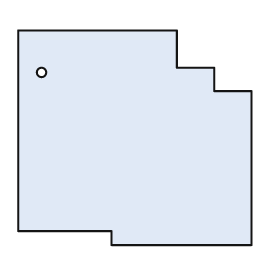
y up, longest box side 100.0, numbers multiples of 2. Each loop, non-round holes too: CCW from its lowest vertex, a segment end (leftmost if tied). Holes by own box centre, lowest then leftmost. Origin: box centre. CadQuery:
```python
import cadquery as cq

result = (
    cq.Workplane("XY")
    .moveTo(-10.0, -46.0)
    .lineTo(50.0, -46.0)
    .lineTo(50.0, 20.0)
    .lineTo(34.0, 20.0)
    .lineTo(34.0, 30.0)
    .lineTo(18.0, 30.0)
    .lineTo(18.0, 46.0)
    .lineTo(-50.0, 46.0)
    .lineTo(-50.0, -40.0)
    .lineTo(-10.0, -40.0)
    .close()
    .moveTo(-40.0, 28.0)
    .circle(2.0)
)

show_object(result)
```